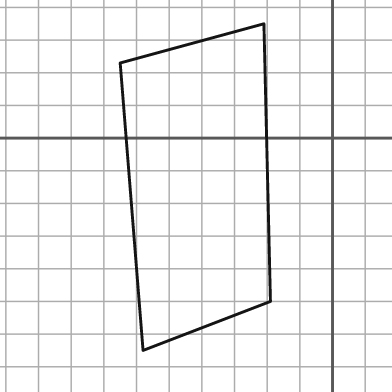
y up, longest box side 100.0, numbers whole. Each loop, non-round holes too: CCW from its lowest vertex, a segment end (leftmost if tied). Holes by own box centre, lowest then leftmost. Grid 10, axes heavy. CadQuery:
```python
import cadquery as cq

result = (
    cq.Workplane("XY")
    .moveTo(-58.0, -65.0)
    .lineTo(-19.0, -50.0)
    .lineTo(-21.0, 35.0)
    .lineTo(-65.0, 23.0)
    .close()
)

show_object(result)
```